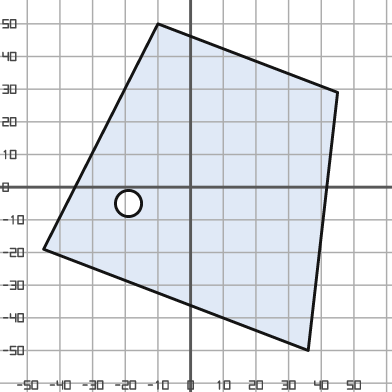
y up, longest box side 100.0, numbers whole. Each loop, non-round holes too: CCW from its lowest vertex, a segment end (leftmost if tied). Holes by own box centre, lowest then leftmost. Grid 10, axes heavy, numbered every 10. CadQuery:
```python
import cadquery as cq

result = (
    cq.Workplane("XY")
    .moveTo(36.0, -50.0)
    .lineTo(45.0, 29.0)
    .lineTo(-10.0, 50.0)
    .lineTo(-45.0, -19.0)
    .close()
    .moveTo(-19.0, -5.0)
    .circle(4.0)
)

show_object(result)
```